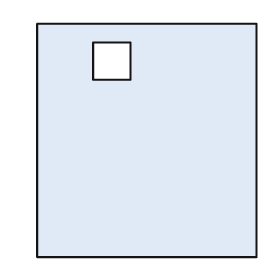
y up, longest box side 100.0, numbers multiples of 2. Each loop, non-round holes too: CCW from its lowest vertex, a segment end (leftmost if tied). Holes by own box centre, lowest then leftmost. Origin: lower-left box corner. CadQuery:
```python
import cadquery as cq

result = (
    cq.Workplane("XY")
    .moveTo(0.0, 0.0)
    .lineTo(94.0, 0.0)
    .lineTo(94.0, 100.0)
    .lineTo(0.0, 100.0)
    .close()
    .moveTo(24.0, 76.0)
    .lineTo(40.0, 76.0)
    .lineTo(40.0, 92.0)
    .lineTo(24.0, 92.0)
    .close()
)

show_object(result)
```